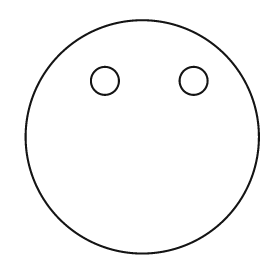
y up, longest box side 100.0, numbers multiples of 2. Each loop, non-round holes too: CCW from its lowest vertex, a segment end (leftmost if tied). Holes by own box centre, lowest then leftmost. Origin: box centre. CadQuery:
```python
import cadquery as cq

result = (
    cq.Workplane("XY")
    .moveTo(0.0, 0.0)
    .circle(50.0)
    .moveTo(-16.0, 24.0)
    .circle(6.0)
    .moveTo(22.0, 24.0)
    .circle(6.0)
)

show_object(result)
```